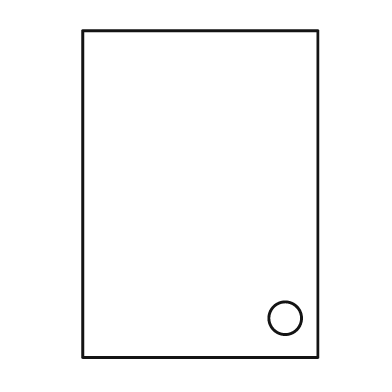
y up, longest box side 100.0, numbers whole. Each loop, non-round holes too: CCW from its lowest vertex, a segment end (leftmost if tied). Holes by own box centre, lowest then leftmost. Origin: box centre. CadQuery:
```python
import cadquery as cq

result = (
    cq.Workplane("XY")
    .moveTo(-36.0, -50.0)
    .lineTo(36.0, -50.0)
    .lineTo(36.0, 50.0)
    .lineTo(-36.0, 50.0)
    .close()
    .moveTo(26.0, -38.0)
    .circle(5.0)
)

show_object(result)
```